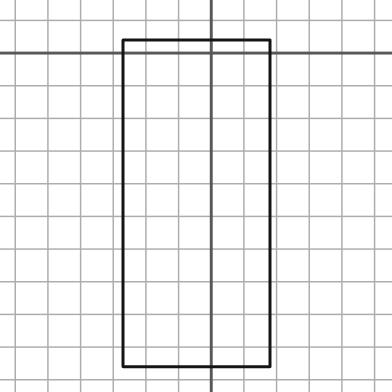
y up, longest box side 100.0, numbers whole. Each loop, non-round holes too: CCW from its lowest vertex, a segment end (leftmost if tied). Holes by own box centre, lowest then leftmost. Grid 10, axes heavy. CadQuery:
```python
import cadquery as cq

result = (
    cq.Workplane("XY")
    .moveTo(-27.0, -96.0)
    .lineTo(18.0, -96.0)
    .lineTo(18.0, 4.0)
    .lineTo(-27.0, 4.0)
    .close()
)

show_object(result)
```